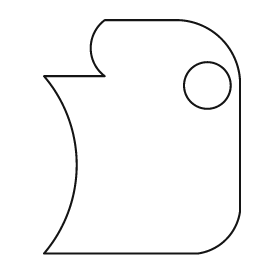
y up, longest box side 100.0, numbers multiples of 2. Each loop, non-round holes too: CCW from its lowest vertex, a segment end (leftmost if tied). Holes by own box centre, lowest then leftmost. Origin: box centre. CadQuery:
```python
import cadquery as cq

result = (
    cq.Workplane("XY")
    .moveTo(-42.0, -50.0)
    .lineTo(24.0, -50.0)
    .threePointArc((36.0, -44.0), (42.0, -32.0))
    .lineTo(42.0, 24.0)
    .threePointArc((34.0, 42.0), (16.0, 50.0))
    .lineTo(-16.0, 50.0)
    .threePointArc((-22.0, 38.0), (-16.0, 26.0))
    .lineTo(-42.0, 26.0)
    .threePointArc((-28.0, -12.0), (-42.0, -50.0))
    .close()
    .moveTo(28.0, 22.0)
    .circle(10.0)
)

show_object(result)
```